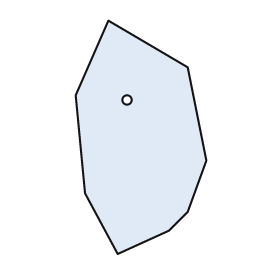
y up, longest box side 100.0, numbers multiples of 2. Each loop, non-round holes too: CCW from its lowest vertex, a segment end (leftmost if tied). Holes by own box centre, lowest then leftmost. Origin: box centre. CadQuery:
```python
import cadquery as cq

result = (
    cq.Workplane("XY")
    .moveTo(-10.0, -50.0)
    .lineTo(12.0, -40.0)
    .lineTo(20.0, -32.0)
    .lineTo(28.0, -10.0)
    .lineTo(20.0, 30.0)
    .lineTo(-14.0, 50.0)
    .lineTo(-28.0, 18.0)
    .lineTo(-24.0, -24.0)
    .close()
    .moveTo(-6.0, 16.0)
    .circle(2.0)
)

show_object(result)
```